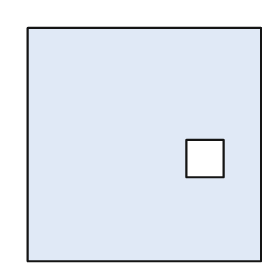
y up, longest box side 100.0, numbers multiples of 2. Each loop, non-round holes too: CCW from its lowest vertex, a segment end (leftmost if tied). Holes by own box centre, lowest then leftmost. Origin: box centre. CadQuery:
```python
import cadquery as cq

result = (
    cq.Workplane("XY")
    .moveTo(-50.0, -50.0)
    .lineTo(50.0, -50.0)
    .lineTo(50.0, 50.0)
    .lineTo(-50.0, 50.0)
    .close()
    .moveTo(18.0, -14.0)
    .lineTo(34.0, -14.0)
    .lineTo(34.0, 2.0)
    .lineTo(18.0, 2.0)
    .close()
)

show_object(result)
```